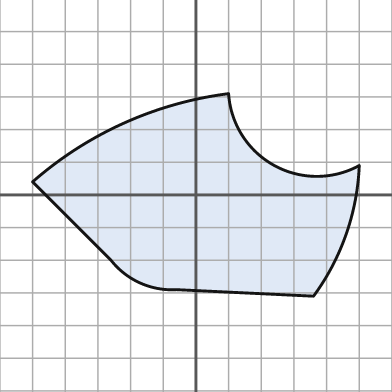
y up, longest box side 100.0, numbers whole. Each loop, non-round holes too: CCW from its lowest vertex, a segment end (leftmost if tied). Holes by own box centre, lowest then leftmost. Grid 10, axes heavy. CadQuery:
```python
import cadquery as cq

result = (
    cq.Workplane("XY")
    .moveTo(36.0, -31.0)
    .threePointArc((46.0, -12.0), (50.0, 9.0))
    .threePointArc((24.0, 9.0), (10.0, 31.0))
    .threePointArc((-22.0, 22.0), (-50.0, 4.0))
    .lineTo(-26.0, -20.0)
    .threePointArc((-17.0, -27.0), (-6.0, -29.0))
    .close()
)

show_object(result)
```